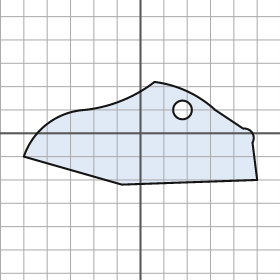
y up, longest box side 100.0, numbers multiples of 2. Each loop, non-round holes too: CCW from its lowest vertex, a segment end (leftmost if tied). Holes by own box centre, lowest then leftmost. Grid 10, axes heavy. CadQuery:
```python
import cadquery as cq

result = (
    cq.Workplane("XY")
    .moveTo(-8.0, -22.0)
    .lineTo(50.0, -20.0)
    .lineTo(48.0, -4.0)
    .threePointArc((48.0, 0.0), (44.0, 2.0))
    .lineTo(32.0, 10.0)
    .threePointArc((20.0, 18.0), (6.0, 22.0))
    .threePointArc((-8.0, 14.0), (-24.0, 10.0))
    .threePointArc((-40.0, 4.0), (-50.0, -10.0))
    .close()
    .moveTo(18.0, 10.0)
    .circle(4.0)
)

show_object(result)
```